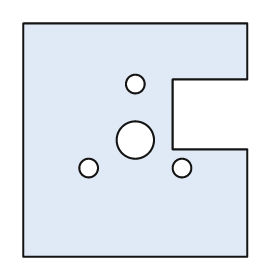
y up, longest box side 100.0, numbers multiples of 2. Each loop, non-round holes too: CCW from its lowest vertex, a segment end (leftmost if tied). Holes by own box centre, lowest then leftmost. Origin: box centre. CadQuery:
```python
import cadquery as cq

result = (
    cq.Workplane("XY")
    .moveTo(-48.0, -50.0)
    .lineTo(48.0, -50.0)
    .lineTo(48.0, -4.0)
    .lineTo(16.0, -4.0)
    .lineTo(16.0, 26.0)
    .lineTo(48.0, 26.0)
    .lineTo(48.0, 50.0)
    .lineTo(-48.0, 50.0)
    .close()
    .moveTo(-20.0, -12.0)
    .circle(4.0)
    .moveTo(20.0, -12.0)
    .circle(4.0)
    .moveTo(0.0, 0.0)
    .circle(8.0)
    .moveTo(0.0, 24.0)
    .circle(4.0)
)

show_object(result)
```